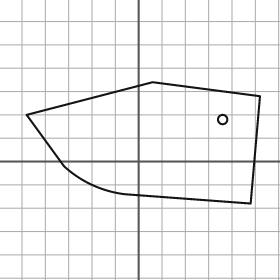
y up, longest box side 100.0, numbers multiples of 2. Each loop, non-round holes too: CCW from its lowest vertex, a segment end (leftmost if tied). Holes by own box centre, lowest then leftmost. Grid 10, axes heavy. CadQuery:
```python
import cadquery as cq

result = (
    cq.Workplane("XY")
    .moveTo(48.0, -18.0)
    .lineTo(52.0, 28.0)
    .lineTo(6.0, 34.0)
    .lineTo(-48.0, 20.0)
    .lineTo(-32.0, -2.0)
    .threePointArc((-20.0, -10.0), (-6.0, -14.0))
    .close()
    .moveTo(36.0, 18.0)
    .circle(2.0)
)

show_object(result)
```